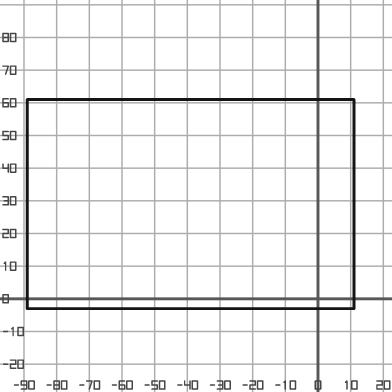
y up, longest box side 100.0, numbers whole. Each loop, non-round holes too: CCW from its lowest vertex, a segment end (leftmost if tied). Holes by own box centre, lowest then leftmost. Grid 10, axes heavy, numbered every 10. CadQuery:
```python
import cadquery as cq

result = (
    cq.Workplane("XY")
    .moveTo(-89.0, -3.0)
    .lineTo(11.0, -3.0)
    .lineTo(11.0, 61.0)
    .lineTo(-89.0, 61.0)
    .close()
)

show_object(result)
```